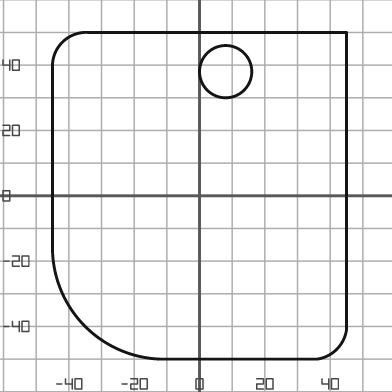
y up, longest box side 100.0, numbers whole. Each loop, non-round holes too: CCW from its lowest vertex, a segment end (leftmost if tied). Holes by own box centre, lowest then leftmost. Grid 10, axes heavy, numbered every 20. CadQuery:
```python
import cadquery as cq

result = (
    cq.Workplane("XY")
    .moveTo(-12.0, -50.0)
    .lineTo(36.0, -50.0)
    .threePointArc((42.0, -47.0), (45.0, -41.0))
    .lineTo(45.0, 50.0)
    .lineTo(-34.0, 50.0)
    .threePointArc((-42.0, 47.0), (-45.0, 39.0))
    .lineTo(-45.0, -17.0)
    .threePointArc((-35.0, -40.0), (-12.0, -50.0))
    .close()
    .moveTo(8.0, 38.0)
    .circle(8.0)
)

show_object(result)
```